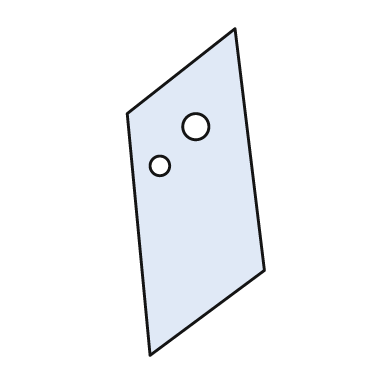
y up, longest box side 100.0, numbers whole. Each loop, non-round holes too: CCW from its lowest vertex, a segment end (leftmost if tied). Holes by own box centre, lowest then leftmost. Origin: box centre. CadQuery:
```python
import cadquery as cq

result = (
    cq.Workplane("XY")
    .moveTo(-14.0, -50.0)
    .lineTo(21.0, -24.0)
    .lineTo(12.0, 50.0)
    .lineTo(-21.0, 24.0)
    .close()
    .moveTo(-11.0, 8.0)
    .circle(3.0)
    .moveTo(0.0, 20.0)
    .circle(4.0)
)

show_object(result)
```